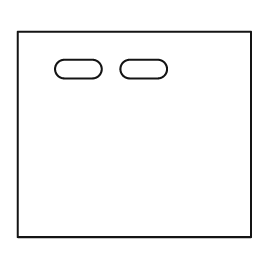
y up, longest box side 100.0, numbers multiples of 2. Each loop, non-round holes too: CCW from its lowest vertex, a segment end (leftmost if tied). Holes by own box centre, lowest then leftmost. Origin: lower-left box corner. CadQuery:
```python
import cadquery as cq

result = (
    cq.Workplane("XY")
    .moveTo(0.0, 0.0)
    .lineTo(100.0, 0.0)
    .lineTo(100.0, 88.0)
    .lineTo(0.0, 88.0)
    .close()
    .moveTo(20.0, 68.0)
    .lineTo(32.0, 68.0)
    .threePointArc((36.0, 72.0), (32.0, 76.0))
    .lineTo(20.0, 76.0)
    .threePointArc((16.0, 72.0), (20.0, 68.0))
    .close()
    .moveTo(48.0, 68.0)
    .lineTo(60.0, 68.0)
    .threePointArc((64.0, 72.0), (60.0, 76.0))
    .lineTo(48.0, 76.0)
    .threePointArc((44.0, 72.0), (48.0, 68.0))
    .close()
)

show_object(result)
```